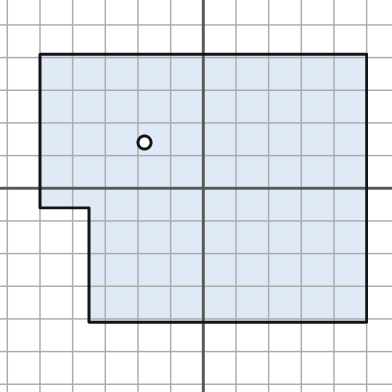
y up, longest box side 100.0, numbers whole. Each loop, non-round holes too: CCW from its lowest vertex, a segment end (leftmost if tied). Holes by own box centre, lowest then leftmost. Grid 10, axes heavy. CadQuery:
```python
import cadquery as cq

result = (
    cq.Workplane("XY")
    .moveTo(-35.0, -41.0)
    .lineTo(50.0, -41.0)
    .lineTo(50.0, 41.0)
    .lineTo(-50.0, 41.0)
    .lineTo(-50.0, -6.0)
    .lineTo(-35.0, -6.0)
    .close()
    .moveTo(-18.0, 14.0)
    .circle(2.0)
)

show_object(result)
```